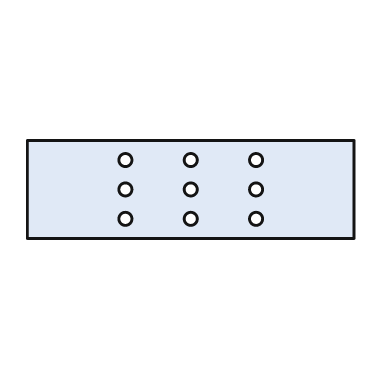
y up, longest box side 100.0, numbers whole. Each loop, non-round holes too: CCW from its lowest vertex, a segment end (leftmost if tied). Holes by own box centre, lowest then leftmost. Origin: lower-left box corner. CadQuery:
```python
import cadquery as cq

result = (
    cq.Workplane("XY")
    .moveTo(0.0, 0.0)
    .lineTo(100.0, 0.0)
    .lineTo(100.0, 30.0)
    .lineTo(0.0, 30.0)
    .close()
    .moveTo(30.0, 6.0)
    .circle(2.0)
    .moveTo(50.0, 6.0)
    .circle(2.0)
    .moveTo(70.0, 6.0)
    .circle(2.0)
    .moveTo(30.0, 15.0)
    .circle(2.0)
    .moveTo(50.0, 15.0)
    .circle(2.0)
    .moveTo(70.0, 15.0)
    .circle(2.0)
    .moveTo(30.0, 24.0)
    .circle(2.0)
    .moveTo(50.0, 24.0)
    .circle(2.0)
    .moveTo(70.0, 24.0)
    .circle(2.0)
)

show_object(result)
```